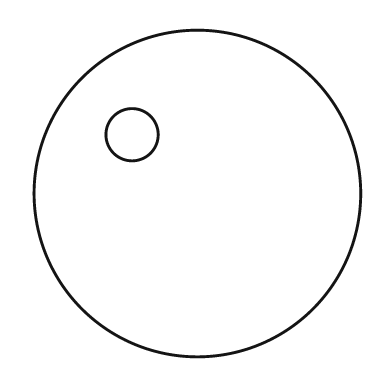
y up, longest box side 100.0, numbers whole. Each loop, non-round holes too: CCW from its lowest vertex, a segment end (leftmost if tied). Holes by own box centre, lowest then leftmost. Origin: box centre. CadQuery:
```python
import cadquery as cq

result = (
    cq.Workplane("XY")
    .moveTo(0.0, 0.0)
    .circle(50.0)
    .moveTo(-20.0, 18.0)
    .circle(8.0)
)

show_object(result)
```